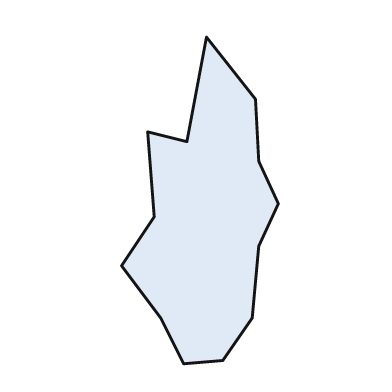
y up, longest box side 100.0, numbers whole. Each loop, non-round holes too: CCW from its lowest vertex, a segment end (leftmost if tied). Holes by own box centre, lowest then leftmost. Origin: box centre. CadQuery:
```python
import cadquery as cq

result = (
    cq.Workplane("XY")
    .moveTo(-5.0, -50.0)
    .lineTo(7.0, -49.0)
    .lineTo(16.0, -36.0)
    .lineTo(18.0, -14.0)
    .lineTo(24.0, -1.0)
    .lineTo(18.0, 12.0)
    .lineTo(17.0, 31.0)
    .lineTo(2.0, 50.0)
    .lineTo(-4.0, 18.0)
    .lineTo(-16.0, 21.0)
    .lineTo(-14.0, -5.0)
    .lineTo(-24.0, -20.0)
    .lineTo(-12.0, -36.0)
    .close()
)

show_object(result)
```